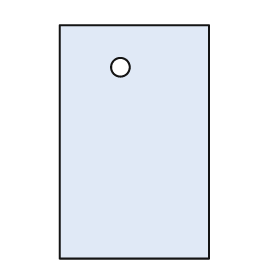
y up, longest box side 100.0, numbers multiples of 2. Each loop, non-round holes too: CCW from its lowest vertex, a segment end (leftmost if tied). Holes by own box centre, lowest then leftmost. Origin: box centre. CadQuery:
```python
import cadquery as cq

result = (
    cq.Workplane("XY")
    .moveTo(-32.0, -50.0)
    .lineTo(32.0, -50.0)
    .lineTo(32.0, 50.0)
    .lineTo(-32.0, 50.0)
    .close()
    .moveTo(-6.0, 32.0)
    .circle(4.0)
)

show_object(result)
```